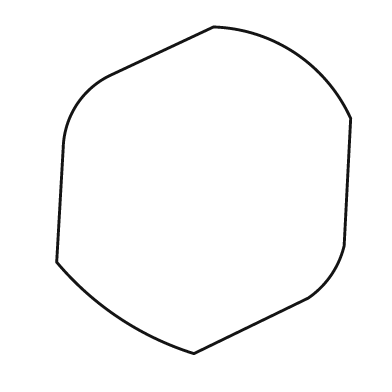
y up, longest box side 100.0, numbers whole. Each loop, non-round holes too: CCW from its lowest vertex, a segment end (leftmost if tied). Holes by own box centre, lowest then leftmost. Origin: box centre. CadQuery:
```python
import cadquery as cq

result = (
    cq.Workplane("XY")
    .moveTo(-3.0, -50.0)
    .lineTo(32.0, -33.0)
    .threePointArc((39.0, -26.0), (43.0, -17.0))
    .lineTo(45.0, 22.0)
    .threePointArc((28.0, 42.0), (3.0, 50.0))
    .lineTo(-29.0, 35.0)
    .threePointArc((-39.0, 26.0), (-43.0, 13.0))
    .lineTo(-45.0, -22.0)
    .threePointArc((-26.0, -39.0), (-3.0, -50.0))
    .close()
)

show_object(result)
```